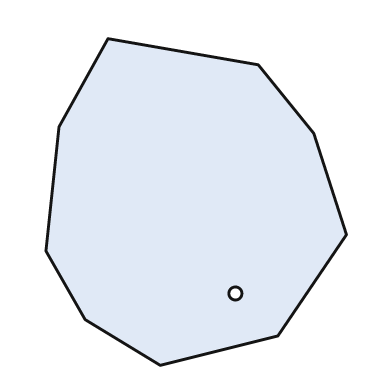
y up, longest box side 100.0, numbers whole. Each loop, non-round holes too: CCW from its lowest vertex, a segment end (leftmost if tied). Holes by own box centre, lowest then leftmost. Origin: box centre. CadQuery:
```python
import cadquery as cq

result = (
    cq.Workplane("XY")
    .moveTo(-11.0, -50.0)
    .lineTo(25.0, -41.0)
    .lineTo(46.0, -10.0)
    .lineTo(36.0, 21.0)
    .lineTo(19.0, 42.0)
    .lineTo(-27.0, 50.0)
    .lineTo(-42.0, 23.0)
    .lineTo(-46.0, -15.0)
    .lineTo(-34.0, -36.0)
    .close()
    .moveTo(12.0, -28.0)
    .circle(2.0)
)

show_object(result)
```